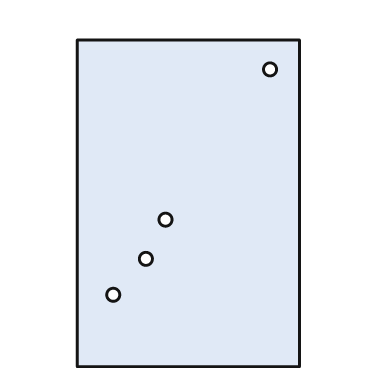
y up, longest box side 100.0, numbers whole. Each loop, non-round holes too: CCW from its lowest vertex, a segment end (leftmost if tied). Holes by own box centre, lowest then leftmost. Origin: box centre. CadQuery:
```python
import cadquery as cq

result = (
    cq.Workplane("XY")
    .moveTo(-34.0, -50.0)
    .lineTo(34.0, -50.0)
    .lineTo(34.0, 50.0)
    .lineTo(-34.0, 50.0)
    .close()
    .moveTo(-23.0, -28.0)
    .circle(2.0)
    .moveTo(-13.0, -17.0)
    .circle(2.0)
    .moveTo(-7.0, -5.0)
    .circle(2.0)
    .moveTo(25.0, 41.0)
    .circle(2.0)
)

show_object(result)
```